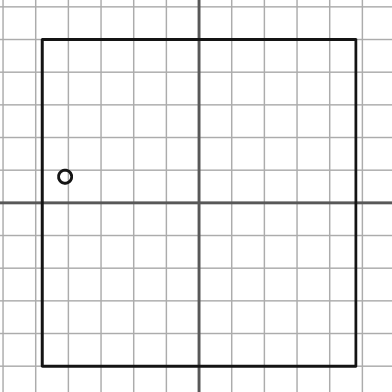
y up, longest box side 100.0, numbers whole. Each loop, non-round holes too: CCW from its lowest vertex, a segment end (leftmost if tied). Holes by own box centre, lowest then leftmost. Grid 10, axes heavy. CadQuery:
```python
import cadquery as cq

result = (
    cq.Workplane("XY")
    .moveTo(-48.0, -50.0)
    .lineTo(48.0, -50.0)
    .lineTo(48.0, 50.0)
    .lineTo(-48.0, 50.0)
    .close()
    .moveTo(-41.0, 8.0)
    .circle(2.0)
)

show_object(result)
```